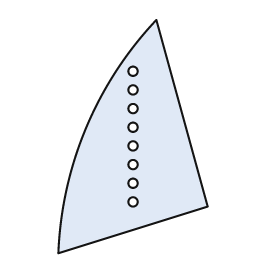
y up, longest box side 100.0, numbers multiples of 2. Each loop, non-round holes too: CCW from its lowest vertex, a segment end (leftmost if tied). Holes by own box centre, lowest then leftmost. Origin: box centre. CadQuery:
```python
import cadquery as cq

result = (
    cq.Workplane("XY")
    .moveTo(-32.0, -50.0)
    .lineTo(32.0, -30.0)
    .lineTo(10.0, 50.0)
    .threePointArc((-20.0, 4.0), (-32.0, -50.0))
    .close()
    .moveTo(0.0, -28.0)
    .circle(2.0)
    .moveTo(0.0, -20.0)
    .circle(2.0)
    .moveTo(0.0, -12.0)
    .circle(2.0)
    .moveTo(0.0, -4.0)
    .circle(2.0)
    .moveTo(0.0, 4.0)
    .circle(2.0)
    .moveTo(0.0, 12.0)
    .circle(2.0)
    .moveTo(0.0, 20.0)
    .circle(2.0)
    .moveTo(0.0, 28.0)
    .circle(2.0)
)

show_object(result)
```